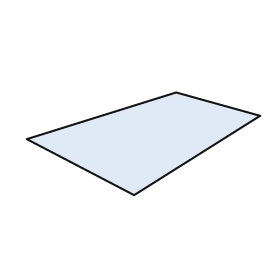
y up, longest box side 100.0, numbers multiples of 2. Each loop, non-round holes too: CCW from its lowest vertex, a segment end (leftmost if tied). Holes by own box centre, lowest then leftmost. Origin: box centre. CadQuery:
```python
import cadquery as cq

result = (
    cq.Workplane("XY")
    .moveTo(-4.0, -22.0)
    .lineTo(50.0, 12.0)
    .lineTo(14.0, 22.0)
    .lineTo(-50.0, 2.0)
    .close()
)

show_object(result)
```